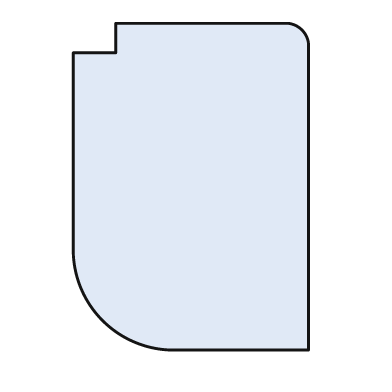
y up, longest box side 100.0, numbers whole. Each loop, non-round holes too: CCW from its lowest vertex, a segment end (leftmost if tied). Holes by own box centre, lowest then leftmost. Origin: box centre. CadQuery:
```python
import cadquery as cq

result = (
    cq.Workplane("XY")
    .moveTo(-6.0, -50.0)
    .lineTo(36.0, -50.0)
    .lineTo(36.0, 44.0)
    .threePointArc((34.0, 48.0), (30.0, 50.0))
    .lineTo(-23.0, 50.0)
    .lineTo(-23.0, 41.0)
    .lineTo(-36.0, 41.0)
    .lineTo(-36.0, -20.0)
    .threePointArc((-27.0, -41.0), (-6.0, -50.0))
    .close()
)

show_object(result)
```